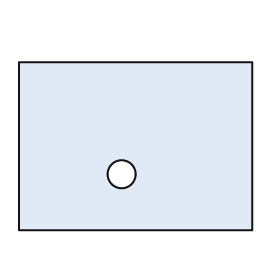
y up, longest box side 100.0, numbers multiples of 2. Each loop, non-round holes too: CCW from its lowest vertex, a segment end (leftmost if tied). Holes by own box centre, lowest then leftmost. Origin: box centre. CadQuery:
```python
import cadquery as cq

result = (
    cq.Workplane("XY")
    .moveTo(-50.0, -36.0)
    .lineTo(50.0, -36.0)
    .lineTo(50.0, 36.0)
    .lineTo(-50.0, 36.0)
    .close()
    .moveTo(-6.0, -12.0)
    .circle(6.0)
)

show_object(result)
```